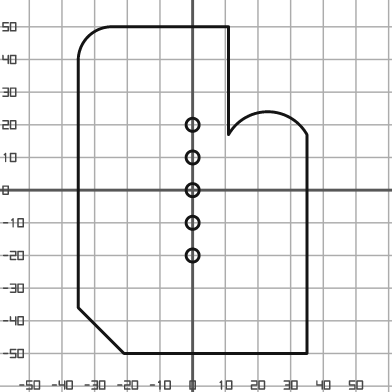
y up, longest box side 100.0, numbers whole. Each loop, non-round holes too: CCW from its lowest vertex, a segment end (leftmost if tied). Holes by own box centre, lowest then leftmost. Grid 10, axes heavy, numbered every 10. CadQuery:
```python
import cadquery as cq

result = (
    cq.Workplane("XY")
    .moveTo(-21.0, -50.0)
    .lineTo(35.0, -50.0)
    .lineTo(35.0, 17.0)
    .threePointArc((23.0, 24.0), (11.0, 17.0))
    .lineTo(11.0, 50.0)
    .lineTo(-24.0, 50.0)
    .threePointArc((-32.0, 47.0), (-35.0, 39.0))
    .lineTo(-35.0, -36.0)
    .close()
    .moveTo(0.0, -20.0)
    .circle(2.0)
    .moveTo(0.0, -10.0)
    .circle(2.0)
    .moveTo(0.0, 0.0)
    .circle(2.0)
    .moveTo(0.0, 10.0)
    .circle(2.0)
    .moveTo(0.0, 20.0)
    .circle(2.0)
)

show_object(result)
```